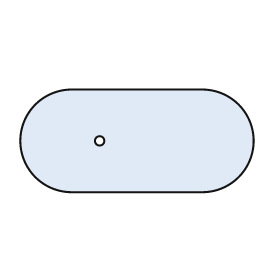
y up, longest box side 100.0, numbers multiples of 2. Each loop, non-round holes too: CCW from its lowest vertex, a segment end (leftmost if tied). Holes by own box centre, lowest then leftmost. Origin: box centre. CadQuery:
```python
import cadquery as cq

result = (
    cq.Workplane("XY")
    .moveTo(-28.0, -22.0)
    .lineTo(28.0, -22.0)
    .threePointArc((50.0, 0.0), (28.0, 22.0))
    .lineTo(-28.0, 22.0)
    .threePointArc((-50.0, 0.0), (-28.0, -22.0))
    .close()
    .moveTo(-16.0, 0.0)
    .circle(2.0)
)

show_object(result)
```